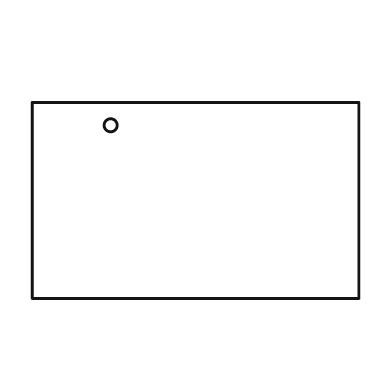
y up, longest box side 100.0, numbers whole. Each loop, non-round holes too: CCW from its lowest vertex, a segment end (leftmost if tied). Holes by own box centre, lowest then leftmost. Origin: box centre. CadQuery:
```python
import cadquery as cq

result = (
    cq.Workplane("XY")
    .moveTo(-50.0, -30.0)
    .lineTo(50.0, -30.0)
    .lineTo(50.0, 30.0)
    .lineTo(-50.0, 30.0)
    .close()
    .moveTo(-26.0, 23.0)
    .circle(2.0)
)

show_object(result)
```